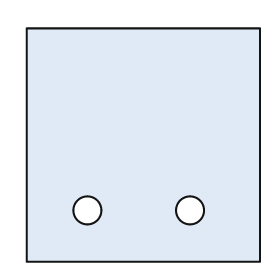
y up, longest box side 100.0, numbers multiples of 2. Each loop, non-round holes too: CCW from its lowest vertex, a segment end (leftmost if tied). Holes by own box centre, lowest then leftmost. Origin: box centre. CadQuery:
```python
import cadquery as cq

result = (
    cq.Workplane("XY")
    .moveTo(-50.0, -50.0)
    .lineTo(50.0, -50.0)
    .lineTo(50.0, 50.0)
    .lineTo(-50.0, 50.0)
    .close()
    .moveTo(-24.0, -28.0)
    .circle(6.0)
    .moveTo(20.0, -28.0)
    .circle(6.0)
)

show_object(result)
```